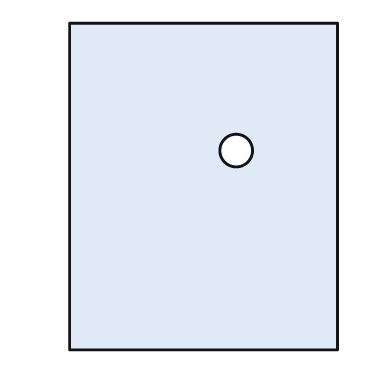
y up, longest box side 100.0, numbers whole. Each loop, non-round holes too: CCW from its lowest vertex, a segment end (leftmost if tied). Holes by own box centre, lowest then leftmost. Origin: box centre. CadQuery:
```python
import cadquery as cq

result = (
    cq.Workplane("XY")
    .moveTo(-41.0, -50.0)
    .lineTo(41.0, -50.0)
    .lineTo(41.0, 50.0)
    .lineTo(-41.0, 50.0)
    .close()
    .moveTo(10.0, 11.0)
    .circle(5.0)
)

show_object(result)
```